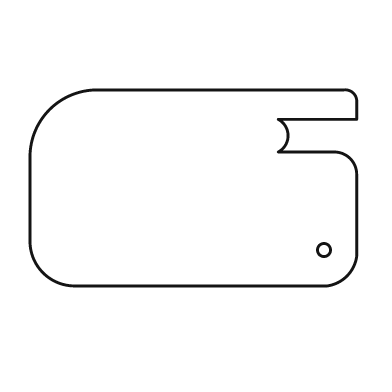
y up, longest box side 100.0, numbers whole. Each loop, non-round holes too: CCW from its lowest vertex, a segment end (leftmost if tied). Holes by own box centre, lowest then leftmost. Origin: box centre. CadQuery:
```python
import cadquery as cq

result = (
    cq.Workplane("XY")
    .moveTo(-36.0, -30.0)
    .lineTo(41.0, -30.0)
    .threePointArc((47.0, -27.0), (50.0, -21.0))
    .lineTo(50.0, 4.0)
    .threePointArc((48.0, 9.0), (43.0, 11.0))
    .lineTo(26.0, 11.0)
    .threePointArc((29.0, 16.0), (26.0, 21.0))
    .lineTo(50.0, 21.0)
    .lineTo(50.0, 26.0)
    .threePointArc((49.0, 29.0), (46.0, 30.0))
    .lineTo(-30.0, 30.0)
    .threePointArc((-44.0, 24.0), (-50.0, 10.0))
    .lineTo(-50.0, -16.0)
    .threePointArc((-46.0, -26.0), (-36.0, -30.0))
    .close()
    .moveTo(40.0, -19.0)
    .circle(2.0)
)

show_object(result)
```